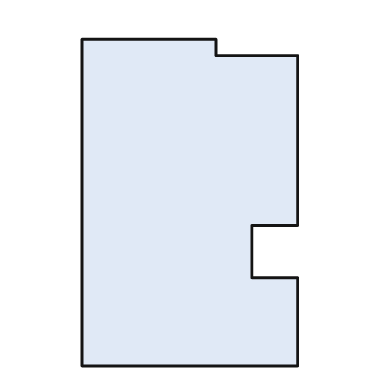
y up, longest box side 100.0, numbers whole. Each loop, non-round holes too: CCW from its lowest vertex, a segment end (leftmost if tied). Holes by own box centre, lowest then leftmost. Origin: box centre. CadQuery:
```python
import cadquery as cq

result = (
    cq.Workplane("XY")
    .moveTo(-33.0, -50.0)
    .lineTo(33.0, -50.0)
    .lineTo(33.0, -23.0)
    .lineTo(19.0, -23.0)
    .lineTo(19.0, -7.0)
    .lineTo(33.0, -7.0)
    .lineTo(33.0, 45.0)
    .lineTo(8.0, 45.0)
    .lineTo(8.0, 50.0)
    .lineTo(-33.0, 50.0)
    .close()
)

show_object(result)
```